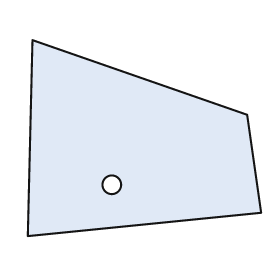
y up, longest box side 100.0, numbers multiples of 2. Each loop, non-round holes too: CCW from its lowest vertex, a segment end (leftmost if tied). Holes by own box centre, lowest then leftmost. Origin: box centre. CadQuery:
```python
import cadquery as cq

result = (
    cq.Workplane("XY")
    .moveTo(-50.0, -42.0)
    .lineTo(50.0, -32.0)
    .lineTo(44.0, 10.0)
    .lineTo(-48.0, 42.0)
    .close()
    .moveTo(-14.0, -20.0)
    .circle(4.0)
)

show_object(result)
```